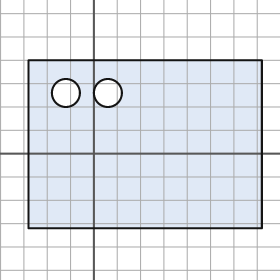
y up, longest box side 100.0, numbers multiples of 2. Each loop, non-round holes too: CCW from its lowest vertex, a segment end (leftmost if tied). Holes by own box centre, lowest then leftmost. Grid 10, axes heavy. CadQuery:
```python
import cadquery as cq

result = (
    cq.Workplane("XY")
    .moveTo(-28.0, -32.0)
    .lineTo(72.0, -32.0)
    .lineTo(72.0, 40.0)
    .lineTo(-28.0, 40.0)
    .close()
    .moveTo(-12.0, 26.0)
    .circle(6.0)
    .moveTo(6.0, 26.0)
    .circle(6.0)
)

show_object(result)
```